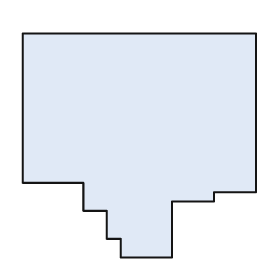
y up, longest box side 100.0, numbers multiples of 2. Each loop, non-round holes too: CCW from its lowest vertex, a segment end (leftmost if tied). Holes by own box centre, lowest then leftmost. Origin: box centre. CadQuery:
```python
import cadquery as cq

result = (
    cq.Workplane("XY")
    .moveTo(-8.0, -48.0)
    .lineTo(14.0, -48.0)
    .lineTo(14.0, -24.0)
    .lineTo(32.0, -24.0)
    .lineTo(32.0, -20.0)
    .lineTo(50.0, -20.0)
    .lineTo(50.0, 48.0)
    .lineTo(-50.0, 48.0)
    .lineTo(-50.0, -16.0)
    .lineTo(-24.0, -16.0)
    .lineTo(-24.0, -28.0)
    .lineTo(-14.0, -28.0)
    .lineTo(-14.0, -40.0)
    .lineTo(-8.0, -40.0)
    .close()
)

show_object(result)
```